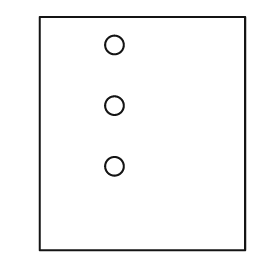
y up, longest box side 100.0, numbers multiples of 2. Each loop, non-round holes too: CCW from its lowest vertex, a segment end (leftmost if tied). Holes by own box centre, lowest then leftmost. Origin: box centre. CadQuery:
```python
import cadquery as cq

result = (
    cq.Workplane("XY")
    .moveTo(-44.0, -50.0)
    .lineTo(44.0, -50.0)
    .lineTo(44.0, 50.0)
    .lineTo(-44.0, 50.0)
    .close()
    .moveTo(-12.0, -14.0)
    .circle(4.0)
    .moveTo(-12.0, 12.0)
    .circle(4.0)
    .moveTo(-12.0, 38.0)
    .circle(4.0)
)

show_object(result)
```